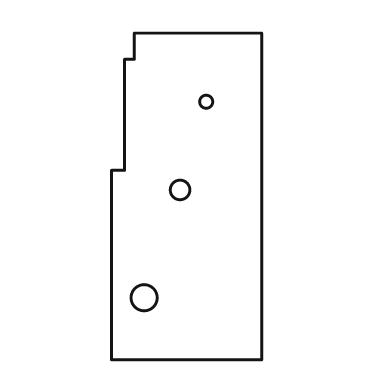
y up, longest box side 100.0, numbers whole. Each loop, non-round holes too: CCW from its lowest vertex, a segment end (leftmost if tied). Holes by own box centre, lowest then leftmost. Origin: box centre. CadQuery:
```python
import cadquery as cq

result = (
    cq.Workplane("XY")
    .moveTo(-23.0, -50.0)
    .lineTo(23.0, -50.0)
    .lineTo(23.0, 50.0)
    .lineTo(-16.0, 50.0)
    .lineTo(-16.0, 42.0)
    .lineTo(-19.0, 42.0)
    .lineTo(-19.0, 8.0)
    .lineTo(-23.0, 8.0)
    .close()
    .moveTo(-13.0, -31.0)
    .circle(4.0)
    .moveTo(-2.0, 2.0)
    .circle(3.0)
    .moveTo(6.0, 29.0)
    .circle(2.0)
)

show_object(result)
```